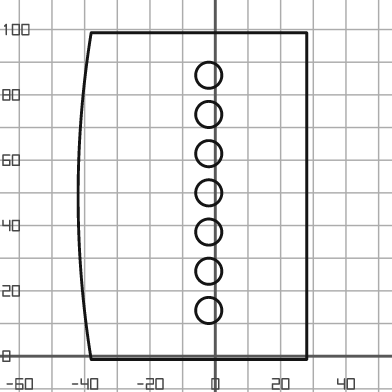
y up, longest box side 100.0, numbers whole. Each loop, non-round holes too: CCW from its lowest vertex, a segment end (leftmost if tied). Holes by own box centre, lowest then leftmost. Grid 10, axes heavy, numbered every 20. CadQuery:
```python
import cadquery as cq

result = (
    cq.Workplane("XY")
    .moveTo(-38.0, -1.0)
    .lineTo(28.0, -1.0)
    .lineTo(28.0, 99.0)
    .lineTo(-38.0, 99.0)
    .threePointArc((-42.0, 49.0), (-38.0, -1.0))
    .close()
    .moveTo(-2.0, 14.0)
    .circle(4.0)
    .moveTo(-2.0, 26.0)
    .circle(4.0)
    .moveTo(-2.0, 38.0)
    .circle(4.0)
    .moveTo(-2.0, 50.0)
    .circle(4.0)
    .moveTo(-2.0, 62.0)
    .circle(4.0)
    .moveTo(-2.0, 74.0)
    .circle(4.0)
    .moveTo(-2.0, 86.0)
    .circle(4.0)
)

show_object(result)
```